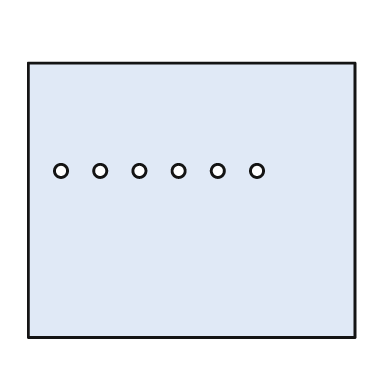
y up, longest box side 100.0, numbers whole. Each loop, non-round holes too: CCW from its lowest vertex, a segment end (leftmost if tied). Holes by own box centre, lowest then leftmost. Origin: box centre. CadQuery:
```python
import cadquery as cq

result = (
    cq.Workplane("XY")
    .moveTo(-50.0, -42.0)
    .lineTo(50.0, -42.0)
    .lineTo(50.0, 42.0)
    .lineTo(-50.0, 42.0)
    .close()
    .moveTo(-40.0, 9.0)
    .circle(2.0)
    .moveTo(-28.0, 9.0)
    .circle(2.0)
    .moveTo(-16.0, 9.0)
    .circle(2.0)
    .moveTo(-4.0, 9.0)
    .circle(2.0)
    .moveTo(8.0, 9.0)
    .circle(2.0)
    .moveTo(20.0, 9.0)
    .circle(2.0)
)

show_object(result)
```